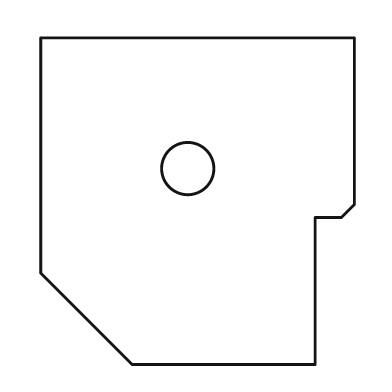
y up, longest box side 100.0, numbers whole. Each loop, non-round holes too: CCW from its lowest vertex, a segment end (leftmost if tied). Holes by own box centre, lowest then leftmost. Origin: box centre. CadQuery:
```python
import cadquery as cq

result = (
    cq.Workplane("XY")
    .moveTo(-20.0, -50.0)
    .lineTo(36.0, -50.0)
    .lineTo(36.0, -5.0)
    .lineTo(44.0, -5.0)
    .lineTo(48.0, -1.0)
    .lineTo(48.0, 50.0)
    .lineTo(-48.0, 50.0)
    .lineTo(-48.0, -22.0)
    .close()
    .moveTo(-3.0, 10.0)
    .circle(8.0)
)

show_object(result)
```